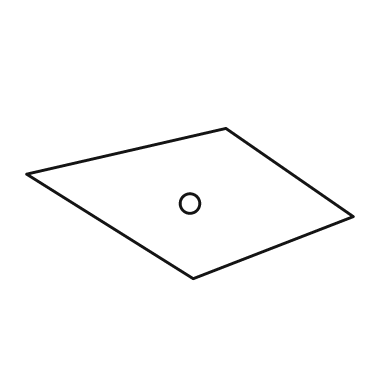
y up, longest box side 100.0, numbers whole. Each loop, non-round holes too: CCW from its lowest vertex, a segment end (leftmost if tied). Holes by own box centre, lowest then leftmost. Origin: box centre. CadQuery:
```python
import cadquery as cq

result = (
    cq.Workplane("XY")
    .moveTo(1.0, -23.0)
    .lineTo(50.0, -4.0)
    .lineTo(11.0, 23.0)
    .lineTo(-50.0, 9.0)
    .close()
    .moveTo(0.0, 0.0)
    .circle(3.0)
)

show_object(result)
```